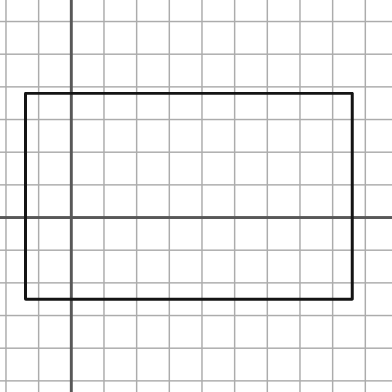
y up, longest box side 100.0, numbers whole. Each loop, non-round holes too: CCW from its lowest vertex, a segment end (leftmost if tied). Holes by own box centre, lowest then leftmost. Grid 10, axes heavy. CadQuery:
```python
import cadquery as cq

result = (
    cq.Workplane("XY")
    .moveTo(-14.0, -25.0)
    .lineTo(86.0, -25.0)
    .lineTo(86.0, 38.0)
    .lineTo(-14.0, 38.0)
    .close()
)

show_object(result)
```